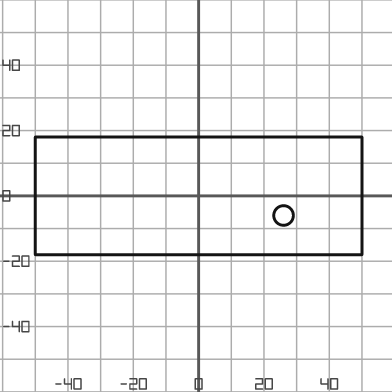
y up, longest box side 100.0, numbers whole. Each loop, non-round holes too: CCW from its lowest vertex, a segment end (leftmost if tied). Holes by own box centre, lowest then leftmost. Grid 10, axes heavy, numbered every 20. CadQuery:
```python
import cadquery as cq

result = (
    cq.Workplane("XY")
    .moveTo(-50.0, -18.0)
    .lineTo(50.0, -18.0)
    .lineTo(50.0, 18.0)
    .lineTo(-50.0, 18.0)
    .close()
    .moveTo(26.0, -6.0)
    .circle(3.0)
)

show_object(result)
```